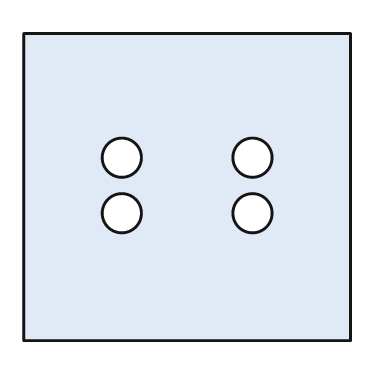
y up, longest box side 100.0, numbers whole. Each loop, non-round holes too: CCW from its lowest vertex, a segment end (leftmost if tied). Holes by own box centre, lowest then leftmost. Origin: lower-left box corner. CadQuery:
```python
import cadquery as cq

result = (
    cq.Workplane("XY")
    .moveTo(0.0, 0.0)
    .lineTo(100.0, 0.0)
    .lineTo(100.0, 94.0)
    .lineTo(0.0, 94.0)
    .close()
    .moveTo(30.0, 39.0)
    .circle(6.0)
    .moveTo(70.0, 39.0)
    .circle(6.0)
    .moveTo(30.0, 56.0)
    .circle(6.0)
    .moveTo(70.0, 56.0)
    .circle(6.0)
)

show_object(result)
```